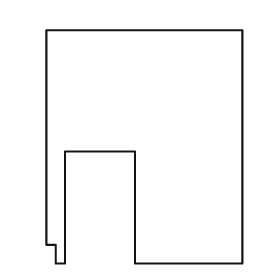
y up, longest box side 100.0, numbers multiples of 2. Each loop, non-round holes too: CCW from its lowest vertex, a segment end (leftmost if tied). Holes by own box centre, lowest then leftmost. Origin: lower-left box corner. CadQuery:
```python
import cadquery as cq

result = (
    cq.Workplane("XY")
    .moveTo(4.0, 0.0)
    .lineTo(8.0, 0.0)
    .lineTo(8.0, 48.0)
    .lineTo(38.0, 48.0)
    .lineTo(38.0, 0.0)
    .lineTo(84.0, 0.0)
    .lineTo(84.0, 100.0)
    .lineTo(0.0, 100.0)
    .lineTo(0.0, 8.0)
    .lineTo(4.0, 8.0)
    .close()
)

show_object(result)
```